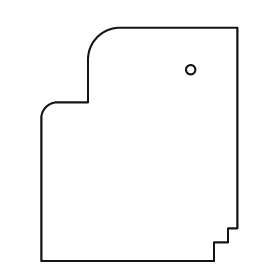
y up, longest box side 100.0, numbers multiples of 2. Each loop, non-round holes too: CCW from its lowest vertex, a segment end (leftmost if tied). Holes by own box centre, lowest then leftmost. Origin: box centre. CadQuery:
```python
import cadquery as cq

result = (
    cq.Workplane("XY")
    .moveTo(-42.0, -50.0)
    .lineTo(32.0, -50.0)
    .lineTo(32.0, -42.0)
    .lineTo(38.0, -42.0)
    .lineTo(38.0, -36.0)
    .lineTo(42.0, -36.0)
    .lineTo(42.0, 50.0)
    .lineTo(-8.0, 50.0)
    .threePointArc((-18.0, 46.0), (-22.0, 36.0))
    .lineTo(-22.0, 18.0)
    .lineTo(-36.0, 18.0)
    .threePointArc((-40.0, 16.0), (-42.0, 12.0))
    .close()
    .moveTo(22.0, 32.0)
    .circle(2.0)
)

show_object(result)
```